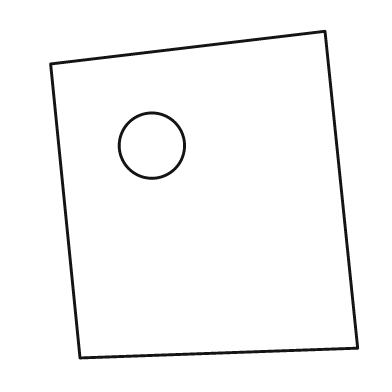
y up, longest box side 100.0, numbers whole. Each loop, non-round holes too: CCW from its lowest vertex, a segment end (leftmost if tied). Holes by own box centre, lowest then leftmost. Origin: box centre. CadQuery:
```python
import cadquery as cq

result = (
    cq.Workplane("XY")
    .moveTo(-38.0, -50.0)
    .lineTo(47.0, -47.0)
    .lineTo(37.0, 50.0)
    .lineTo(-47.0, 40.0)
    .close()
    .moveTo(-16.0, 15.0)
    .circle(10.0)
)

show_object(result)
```